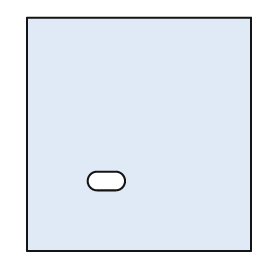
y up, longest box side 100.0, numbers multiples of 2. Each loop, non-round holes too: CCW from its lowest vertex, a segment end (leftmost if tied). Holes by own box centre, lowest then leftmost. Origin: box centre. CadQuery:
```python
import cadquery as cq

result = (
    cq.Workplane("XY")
    .moveTo(-48.0, -50.0)
    .lineTo(48.0, -50.0)
    .lineTo(48.0, 50.0)
    .lineTo(-48.0, 50.0)
    .close()
    .moveTo(-18.0, -24.0)
    .lineTo(-10.0, -24.0)
    .threePointArc((-6.0, -20.0), (-10.0, -16.0))
    .lineTo(-18.0, -16.0)
    .threePointArc((-22.0, -20.0), (-18.0, -24.0))
    .close()
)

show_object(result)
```